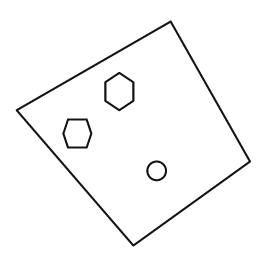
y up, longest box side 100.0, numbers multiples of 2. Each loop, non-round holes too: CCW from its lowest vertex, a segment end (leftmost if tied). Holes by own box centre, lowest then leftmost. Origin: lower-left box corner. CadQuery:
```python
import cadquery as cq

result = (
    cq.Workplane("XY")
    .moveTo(50.0, 0.0)
    .lineTo(100.0, 36.0)
    .lineTo(66.0, 96.0)
    .lineTo(0.0, 58.0)
    .close()
    .moveTo(60.0, 32.0)
    .circle(4.0)
    .moveTo(22.0, 42.0)
    .lineTo(30.0, 42.0)
    .lineTo(32.0, 48.0)
    .lineTo(30.0, 54.0)
    .lineTo(22.0, 54.0)
    .lineTo(20.0, 48.0)
    .close()
    .moveTo(44.0, 58.0)
    .lineTo(50.0, 62.0)
    .lineTo(50.0, 70.0)
    .lineTo(44.0, 74.0)
    .lineTo(38.0, 70.0)
    .lineTo(38.0, 62.0)
    .close()
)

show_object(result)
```